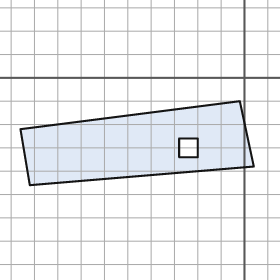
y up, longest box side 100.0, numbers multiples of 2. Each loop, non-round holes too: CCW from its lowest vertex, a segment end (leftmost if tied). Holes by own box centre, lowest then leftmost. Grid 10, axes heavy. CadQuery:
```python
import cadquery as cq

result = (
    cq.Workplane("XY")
    .moveTo(-92.0, -46.0)
    .lineTo(4.0, -38.0)
    .lineTo(-2.0, -10.0)
    .lineTo(-96.0, -22.0)
    .close()
    .moveTo(-28.0, -34.0)
    .lineTo(-20.0, -34.0)
    .lineTo(-20.0, -26.0)
    .lineTo(-28.0, -26.0)
    .close()
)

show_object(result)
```